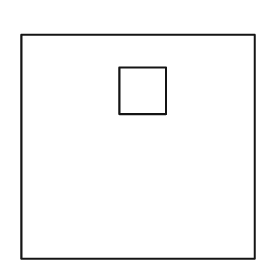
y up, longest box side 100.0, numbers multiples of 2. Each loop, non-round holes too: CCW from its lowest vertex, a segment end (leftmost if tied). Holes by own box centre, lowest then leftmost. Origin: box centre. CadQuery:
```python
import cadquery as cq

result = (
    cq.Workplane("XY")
    .moveTo(-50.0, -48.0)
    .lineTo(50.0, -48.0)
    .lineTo(50.0, 48.0)
    .lineTo(-50.0, 48.0)
    .close()
    .moveTo(-8.0, 14.0)
    .lineTo(12.0, 14.0)
    .lineTo(12.0, 34.0)
    .lineTo(-8.0, 34.0)
    .close()
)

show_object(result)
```